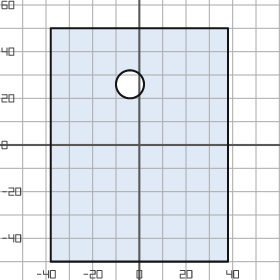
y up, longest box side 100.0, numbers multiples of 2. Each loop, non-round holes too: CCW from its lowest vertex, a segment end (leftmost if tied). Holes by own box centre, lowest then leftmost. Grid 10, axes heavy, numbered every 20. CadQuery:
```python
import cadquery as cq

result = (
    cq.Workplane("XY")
    .moveTo(-38.0, -50.0)
    .lineTo(38.0, -50.0)
    .lineTo(38.0, 50.0)
    .lineTo(-38.0, 50.0)
    .close()
    .moveTo(-4.0, 26.0)
    .circle(6.0)
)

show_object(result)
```